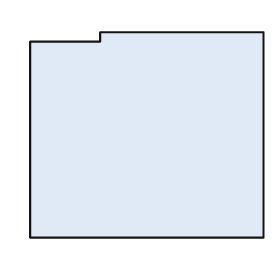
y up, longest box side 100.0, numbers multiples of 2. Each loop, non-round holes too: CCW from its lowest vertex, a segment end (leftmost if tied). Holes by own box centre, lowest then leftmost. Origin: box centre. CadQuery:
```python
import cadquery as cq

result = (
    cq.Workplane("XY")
    .moveTo(-50.0, -44.0)
    .lineTo(50.0, -44.0)
    .lineTo(50.0, 44.0)
    .lineTo(-20.0, 44.0)
    .lineTo(-20.0, 40.0)
    .lineTo(-50.0, 40.0)
    .close()
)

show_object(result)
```